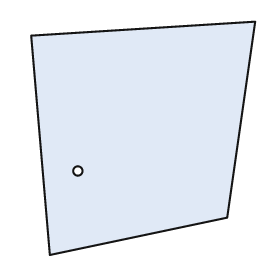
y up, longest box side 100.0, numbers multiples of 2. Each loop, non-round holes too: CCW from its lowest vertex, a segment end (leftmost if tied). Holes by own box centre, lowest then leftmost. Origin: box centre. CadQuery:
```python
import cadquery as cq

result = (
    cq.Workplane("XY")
    .moveTo(-40.0, -50.0)
    .lineTo(36.0, -34.0)
    .lineTo(48.0, 50.0)
    .lineTo(-48.0, 44.0)
    .close()
    .moveTo(-28.0, -14.0)
    .circle(2.0)
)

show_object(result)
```